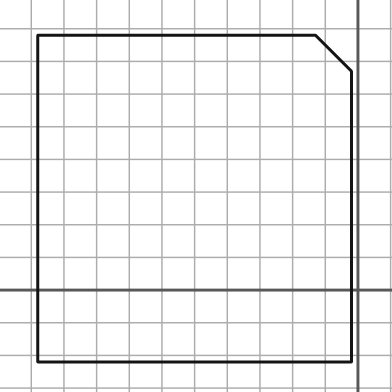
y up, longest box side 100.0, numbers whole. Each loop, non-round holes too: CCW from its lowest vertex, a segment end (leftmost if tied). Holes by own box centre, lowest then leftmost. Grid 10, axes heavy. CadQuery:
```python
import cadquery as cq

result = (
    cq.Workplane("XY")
    .moveTo(-98.0, -22.0)
    .lineTo(-2.0, -22.0)
    .lineTo(-2.0, 67.0)
    .lineTo(-13.0, 78.0)
    .lineTo(-98.0, 78.0)
    .close()
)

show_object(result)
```